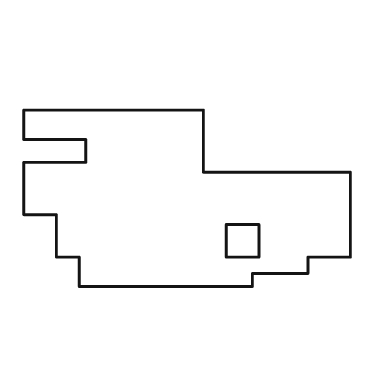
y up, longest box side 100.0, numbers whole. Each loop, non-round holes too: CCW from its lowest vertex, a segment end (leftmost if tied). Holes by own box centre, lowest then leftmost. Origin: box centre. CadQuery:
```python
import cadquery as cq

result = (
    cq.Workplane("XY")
    .moveTo(-33.0, -27.0)
    .lineTo(20.0, -27.0)
    .lineTo(20.0, -23.0)
    .lineTo(37.0, -23.0)
    .lineTo(37.0, -18.0)
    .lineTo(50.0, -18.0)
    .lineTo(50.0, 8.0)
    .lineTo(5.0, 8.0)
    .lineTo(5.0, 27.0)
    .lineTo(-50.0, 27.0)
    .lineTo(-50.0, 18.0)
    .lineTo(-31.0, 18.0)
    .lineTo(-31.0, 11.0)
    .lineTo(-50.0, 11.0)
    .lineTo(-50.0, -5.0)
    .lineTo(-40.0, -5.0)
    .lineTo(-40.0, -18.0)
    .lineTo(-33.0, -18.0)
    .close()
    .moveTo(12.0, -18.0)
    .lineTo(22.0, -18.0)
    .lineTo(22.0, -8.0)
    .lineTo(12.0, -8.0)
    .close()
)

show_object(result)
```